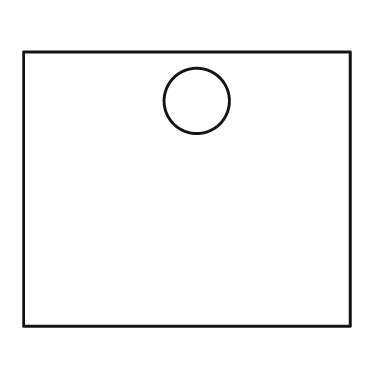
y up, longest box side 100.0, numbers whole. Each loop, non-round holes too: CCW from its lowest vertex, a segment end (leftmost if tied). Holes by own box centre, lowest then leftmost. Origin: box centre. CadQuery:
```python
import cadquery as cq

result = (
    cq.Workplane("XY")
    .moveTo(-50.0, -42.0)
    .lineTo(50.0, -42.0)
    .lineTo(50.0, 42.0)
    .lineTo(-50.0, 42.0)
    .close()
    .moveTo(3.0, 27.0)
    .circle(10.0)
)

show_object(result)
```